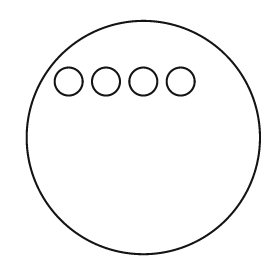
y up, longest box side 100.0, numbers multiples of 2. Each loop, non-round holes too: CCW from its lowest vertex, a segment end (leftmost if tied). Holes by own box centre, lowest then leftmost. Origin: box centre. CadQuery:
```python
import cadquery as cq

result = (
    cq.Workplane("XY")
    .moveTo(0.0, 0.0)
    .circle(50.0)
    .moveTo(-32.0, 24.0)
    .circle(6.0)
    .moveTo(-16.0, 24.0)
    .circle(6.0)
    .moveTo(0.0, 24.0)
    .circle(6.0)
    .moveTo(16.0, 24.0)
    .circle(6.0)
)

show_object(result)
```